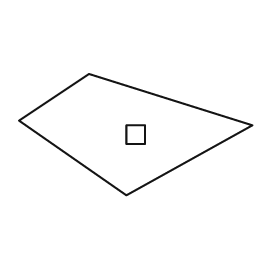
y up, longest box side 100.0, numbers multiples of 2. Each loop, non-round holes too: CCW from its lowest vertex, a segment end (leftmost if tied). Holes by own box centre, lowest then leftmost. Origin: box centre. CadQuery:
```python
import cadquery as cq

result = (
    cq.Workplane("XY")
    .moveTo(-4.0, -26.0)
    .lineTo(50.0, 4.0)
    .lineTo(-20.0, 26.0)
    .lineTo(-50.0, 6.0)
    .close()
    .moveTo(-4.0, -4.0)
    .lineTo(4.0, -4.0)
    .lineTo(4.0, 4.0)
    .lineTo(-4.0, 4.0)
    .close()
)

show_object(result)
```